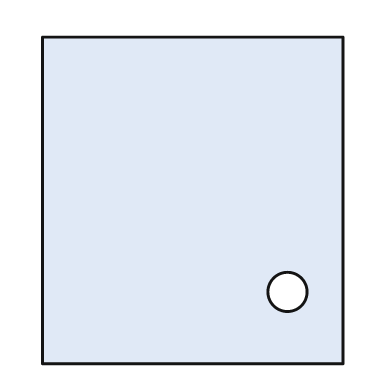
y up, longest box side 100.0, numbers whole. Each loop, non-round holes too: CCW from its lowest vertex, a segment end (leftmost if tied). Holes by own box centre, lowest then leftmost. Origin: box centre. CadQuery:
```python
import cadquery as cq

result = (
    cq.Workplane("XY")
    .moveTo(-46.0, -50.0)
    .lineTo(46.0, -50.0)
    .lineTo(46.0, 50.0)
    .lineTo(-46.0, 50.0)
    .close()
    .moveTo(29.0, -28.0)
    .circle(6.0)
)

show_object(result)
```